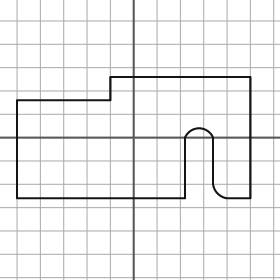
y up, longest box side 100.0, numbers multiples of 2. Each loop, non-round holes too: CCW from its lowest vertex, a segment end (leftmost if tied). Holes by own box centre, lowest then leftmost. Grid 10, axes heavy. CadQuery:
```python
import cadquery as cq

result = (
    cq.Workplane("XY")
    .moveTo(-50.0, -26.0)
    .lineTo(22.0, -26.0)
    .lineTo(22.0, 0.0)
    .threePointArc((28.0, 4.0), (34.0, 0.0))
    .lineTo(34.0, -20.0)
    .threePointArc((36.0, -24.0), (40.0, -26.0))
    .lineTo(50.0, -26.0)
    .lineTo(50.0, 26.0)
    .lineTo(-10.0, 26.0)
    .lineTo(-10.0, 16.0)
    .lineTo(-50.0, 16.0)
    .close()
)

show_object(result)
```